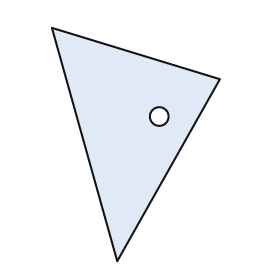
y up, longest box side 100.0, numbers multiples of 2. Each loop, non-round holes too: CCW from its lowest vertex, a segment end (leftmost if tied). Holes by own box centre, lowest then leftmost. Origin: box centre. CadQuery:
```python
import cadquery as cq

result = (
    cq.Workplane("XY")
    .moveTo(-8.0, -50.0)
    .lineTo(36.0, 28.0)
    .lineTo(-36.0, 50.0)
    .close()
    .moveTo(10.0, 12.0)
    .circle(4.0)
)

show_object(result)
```